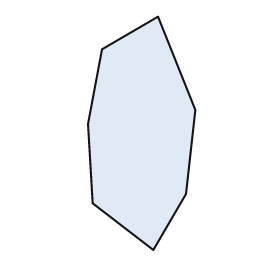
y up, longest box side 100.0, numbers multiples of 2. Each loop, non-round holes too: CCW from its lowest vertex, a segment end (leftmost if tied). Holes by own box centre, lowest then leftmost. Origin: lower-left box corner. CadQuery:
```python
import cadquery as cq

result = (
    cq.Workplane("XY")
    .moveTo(28.0, 0.0)
    .lineTo(42.0, 24.0)
    .lineTo(46.0, 60.0)
    .lineTo(30.0, 100.0)
    .lineTo(6.0, 86.0)
    .lineTo(0.0, 54.0)
    .lineTo(2.0, 20.0)
    .close()
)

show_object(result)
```